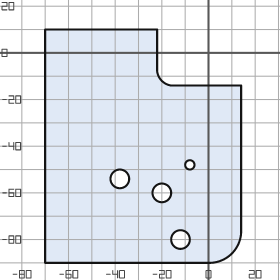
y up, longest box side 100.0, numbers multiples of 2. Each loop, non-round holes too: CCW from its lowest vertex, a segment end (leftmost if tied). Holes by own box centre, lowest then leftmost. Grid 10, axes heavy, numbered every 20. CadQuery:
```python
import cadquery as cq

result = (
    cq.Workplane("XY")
    .moveTo(-70.0, -90.0)
    .lineTo(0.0, -90.0)
    .threePointArc((10.0, -86.0), (14.0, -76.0))
    .lineTo(14.0, -14.0)
    .lineTo(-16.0, -14.0)
    .threePointArc((-20.0, -12.0), (-22.0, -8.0))
    .lineTo(-22.0, 10.0)
    .lineTo(-70.0, 10.0)
    .close()
    .moveTo(-12.0, -80.0)
    .circle(4.0)
    .moveTo(-20.0, -60.0)
    .circle(4.0)
    .moveTo(-38.0, -54.0)
    .circle(4.0)
    .moveTo(-8.0, -48.0)
    .circle(2.0)
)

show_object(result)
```